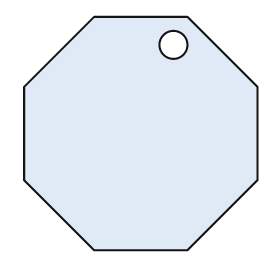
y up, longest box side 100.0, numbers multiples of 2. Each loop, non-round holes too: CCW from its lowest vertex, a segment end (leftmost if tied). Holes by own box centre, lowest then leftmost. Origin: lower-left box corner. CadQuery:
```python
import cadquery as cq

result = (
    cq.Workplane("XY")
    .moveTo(30.0, 0.0)
    .lineTo(70.0, 0.0)
    .lineTo(100.0, 30.0)
    .lineTo(100.0, 70.0)
    .lineTo(70.0, 100.0)
    .lineTo(30.0, 100.0)
    .lineTo(0.0, 70.0)
    .lineTo(0.0, 30.0)
    .close()
    .moveTo(64.0, 88.0)
    .circle(6.0)
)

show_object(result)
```